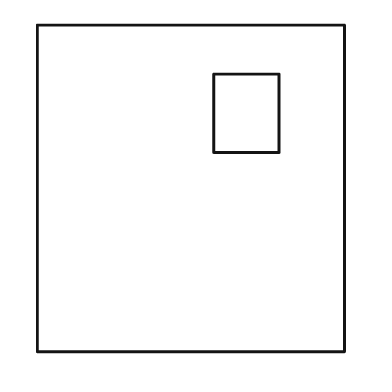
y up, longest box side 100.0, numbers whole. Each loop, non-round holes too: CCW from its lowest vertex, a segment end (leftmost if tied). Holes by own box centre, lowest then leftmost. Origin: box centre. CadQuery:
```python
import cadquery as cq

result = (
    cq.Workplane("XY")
    .moveTo(-47.0, -50.0)
    .lineTo(47.0, -50.0)
    .lineTo(47.0, 50.0)
    .lineTo(-47.0, 50.0)
    .close()
    .moveTo(7.0, 11.0)
    .lineTo(27.0, 11.0)
    .lineTo(27.0, 35.0)
    .lineTo(7.0, 35.0)
    .close()
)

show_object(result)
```